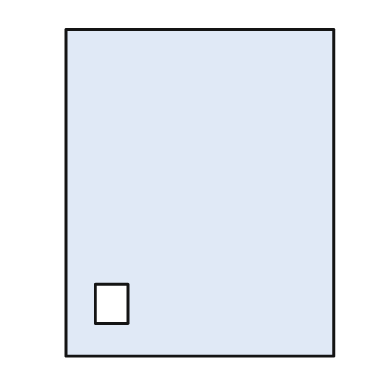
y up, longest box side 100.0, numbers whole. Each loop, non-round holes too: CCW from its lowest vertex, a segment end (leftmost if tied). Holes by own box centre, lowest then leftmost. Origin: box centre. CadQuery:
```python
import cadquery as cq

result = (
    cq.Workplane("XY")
    .moveTo(-41.0, -50.0)
    .lineTo(41.0, -50.0)
    .lineTo(41.0, 50.0)
    .lineTo(-41.0, 50.0)
    .close()
    .moveTo(-32.0, -40.0)
    .lineTo(-22.0, -40.0)
    .lineTo(-22.0, -28.0)
    .lineTo(-32.0, -28.0)
    .close()
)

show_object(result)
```